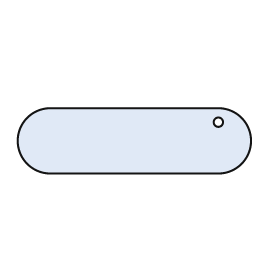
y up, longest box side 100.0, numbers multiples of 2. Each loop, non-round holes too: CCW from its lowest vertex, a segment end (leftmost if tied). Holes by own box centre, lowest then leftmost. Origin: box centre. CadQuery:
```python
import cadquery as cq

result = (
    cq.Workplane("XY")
    .moveTo(-36.0, -14.0)
    .lineTo(36.0, -14.0)
    .threePointArc((50.0, 0.0), (36.0, 14.0))
    .lineTo(-36.0, 14.0)
    .threePointArc((-50.0, 0.0), (-36.0, -14.0))
    .close()
    .moveTo(36.0, 8.0)
    .circle(2.0)
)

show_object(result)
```